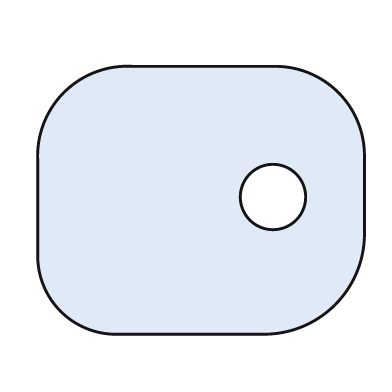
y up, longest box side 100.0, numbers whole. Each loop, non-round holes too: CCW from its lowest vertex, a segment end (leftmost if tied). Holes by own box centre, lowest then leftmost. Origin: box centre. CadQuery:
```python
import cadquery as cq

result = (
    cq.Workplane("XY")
    .moveTo(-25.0, -41.0)
    .lineTo(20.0, -41.0)
    .threePointArc((41.0, -32.0), (50.0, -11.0))
    .lineTo(50.0, 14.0)
    .threePointArc((42.0, 33.0), (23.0, 41.0))
    .lineTo(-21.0, 41.0)
    .threePointArc((-42.0, 33.0), (-50.0, 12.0))
    .lineTo(-50.0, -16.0)
    .threePointArc((-43.0, -34.0), (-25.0, -41.0))
    .close()
    .moveTo(22.0, 1.0)
    .circle(10.0)
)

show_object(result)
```